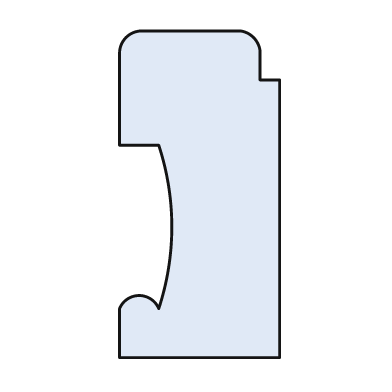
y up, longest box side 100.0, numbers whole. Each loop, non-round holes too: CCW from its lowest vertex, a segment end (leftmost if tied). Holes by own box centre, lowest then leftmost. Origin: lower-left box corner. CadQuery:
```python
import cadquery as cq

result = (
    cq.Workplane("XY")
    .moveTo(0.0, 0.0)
    .lineTo(49.0, 0.0)
    .lineTo(49.0, 85.0)
    .lineTo(43.0, 85.0)
    .lineTo(43.0, 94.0)
    .threePointArc((41.0, 98.0), (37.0, 100.0))
    .lineTo(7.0, 100.0)
    .threePointArc((2.0, 98.0), (0.0, 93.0))
    .lineTo(0.0, 65.0)
    .lineTo(12.0, 65.0)
    .threePointArc((16.0, 40.0), (12.0, 15.0))
    .threePointArc((6.0, 19.0), (0.0, 15.0))
    .close()
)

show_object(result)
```